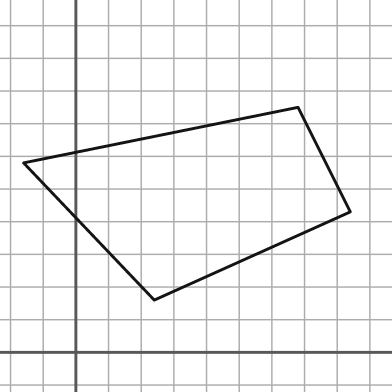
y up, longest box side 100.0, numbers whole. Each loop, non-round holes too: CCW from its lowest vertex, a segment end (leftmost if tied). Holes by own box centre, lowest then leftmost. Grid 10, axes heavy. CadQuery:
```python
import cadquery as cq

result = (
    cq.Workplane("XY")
    .moveTo(24.0, 16.0)
    .lineTo(84.0, 43.0)
    .lineTo(68.0, 75.0)
    .lineTo(-16.0, 58.0)
    .close()
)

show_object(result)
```